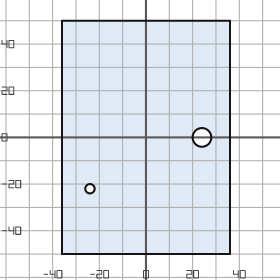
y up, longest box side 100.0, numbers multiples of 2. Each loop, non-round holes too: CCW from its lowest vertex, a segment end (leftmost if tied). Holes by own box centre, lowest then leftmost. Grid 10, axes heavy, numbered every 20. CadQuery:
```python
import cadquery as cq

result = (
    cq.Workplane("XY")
    .moveTo(-36.0, -50.0)
    .lineTo(36.0, -50.0)
    .lineTo(36.0, 50.0)
    .lineTo(-36.0, 50.0)
    .close()
    .moveTo(-24.0, -22.0)
    .circle(2.0)
    .moveTo(24.0, 0.0)
    .circle(4.0)
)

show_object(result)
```